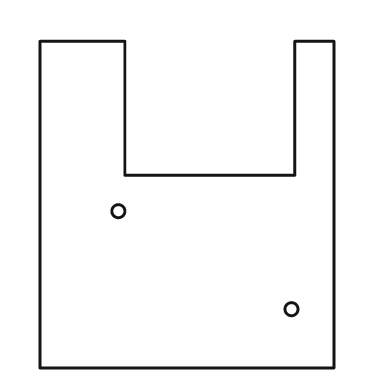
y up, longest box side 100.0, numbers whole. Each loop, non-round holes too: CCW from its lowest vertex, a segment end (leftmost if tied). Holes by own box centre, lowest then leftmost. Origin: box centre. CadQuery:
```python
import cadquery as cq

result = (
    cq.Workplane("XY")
    .moveTo(-45.0, -50.0)
    .lineTo(45.0, -50.0)
    .lineTo(45.0, 50.0)
    .lineTo(33.0, 50.0)
    .lineTo(33.0, 9.0)
    .lineTo(-19.0, 9.0)
    .lineTo(-19.0, 50.0)
    .lineTo(-45.0, 50.0)
    .close()
    .moveTo(32.0, -32.0)
    .circle(2.0)
    .moveTo(-21.0, -2.0)
    .circle(2.0)
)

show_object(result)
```